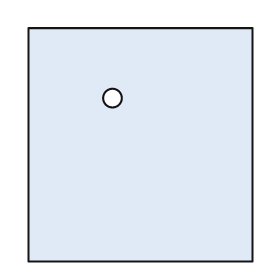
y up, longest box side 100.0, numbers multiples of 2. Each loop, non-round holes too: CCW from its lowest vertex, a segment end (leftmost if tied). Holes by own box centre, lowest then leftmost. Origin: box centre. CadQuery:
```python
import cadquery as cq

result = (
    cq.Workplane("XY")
    .moveTo(-48.0, -50.0)
    .lineTo(48.0, -50.0)
    .lineTo(48.0, 50.0)
    .lineTo(-48.0, 50.0)
    .close()
    .moveTo(-12.0, 20.0)
    .circle(4.0)
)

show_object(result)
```